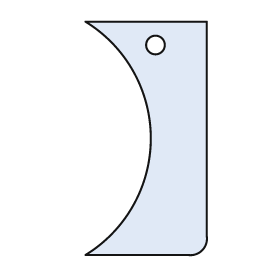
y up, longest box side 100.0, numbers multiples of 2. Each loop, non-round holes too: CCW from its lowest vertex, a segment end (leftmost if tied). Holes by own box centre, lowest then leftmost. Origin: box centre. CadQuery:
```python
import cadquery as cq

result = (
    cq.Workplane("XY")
    .moveTo(-26.0, -50.0)
    .lineTo(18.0, -50.0)
    .threePointArc((24.0, -48.0), (26.0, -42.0))
    .lineTo(26.0, 50.0)
    .lineTo(-26.0, 50.0)
    .threePointArc((2.0, 0.0), (-26.0, -50.0))
    .close()
    .moveTo(4.0, 40.0)
    .circle(4.0)
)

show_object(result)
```